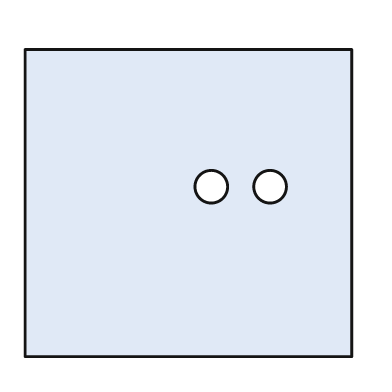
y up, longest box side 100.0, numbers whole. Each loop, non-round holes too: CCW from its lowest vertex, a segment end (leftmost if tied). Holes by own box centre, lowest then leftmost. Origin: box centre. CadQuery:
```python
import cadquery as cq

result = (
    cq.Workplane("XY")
    .moveTo(-50.0, -47.0)
    .lineTo(50.0, -47.0)
    .lineTo(50.0, 47.0)
    .lineTo(-50.0, 47.0)
    .close()
    .moveTo(7.0, 5.0)
    .circle(5.0)
    .moveTo(25.0, 5.0)
    .circle(5.0)
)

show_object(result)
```